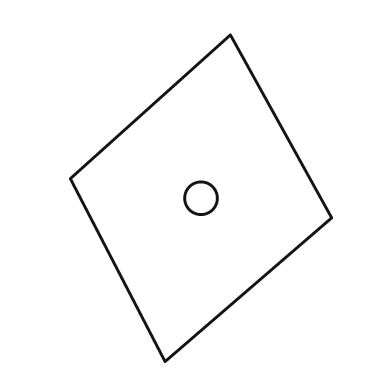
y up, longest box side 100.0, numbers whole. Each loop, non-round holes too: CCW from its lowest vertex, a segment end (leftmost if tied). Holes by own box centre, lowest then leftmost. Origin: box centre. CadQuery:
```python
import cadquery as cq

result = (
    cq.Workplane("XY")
    .moveTo(-11.0, -50.0)
    .lineTo(40.0, -6.0)
    .lineTo(9.0, 50.0)
    .lineTo(-40.0, 6.0)
    .close()
    .moveTo(0.0, 0.0)
    .circle(5.0)
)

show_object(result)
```